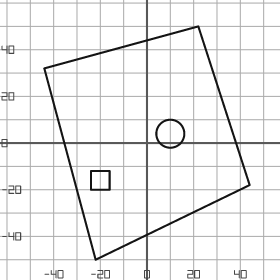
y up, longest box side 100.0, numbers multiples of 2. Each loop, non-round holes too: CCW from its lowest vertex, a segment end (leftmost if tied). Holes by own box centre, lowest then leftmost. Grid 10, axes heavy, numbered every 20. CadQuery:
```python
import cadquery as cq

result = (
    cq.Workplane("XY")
    .moveTo(-22.0, -50.0)
    .lineTo(44.0, -18.0)
    .lineTo(22.0, 50.0)
    .lineTo(-44.0, 32.0)
    .close()
    .moveTo(-24.0, -20.0)
    .lineTo(-16.0, -20.0)
    .lineTo(-16.0, -12.0)
    .lineTo(-24.0, -12.0)
    .close()
    .moveTo(10.0, 4.0)
    .circle(6.0)
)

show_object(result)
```